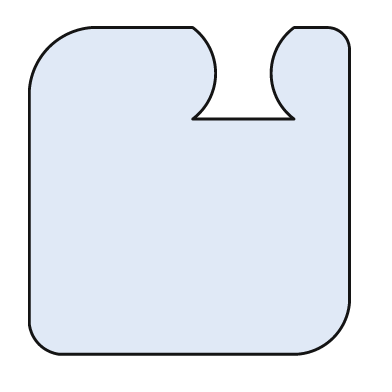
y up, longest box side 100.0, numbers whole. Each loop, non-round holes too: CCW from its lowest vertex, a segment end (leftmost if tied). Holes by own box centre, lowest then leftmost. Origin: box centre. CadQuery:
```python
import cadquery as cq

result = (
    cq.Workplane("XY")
    .moveTo(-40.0, -50.0)
    .lineTo(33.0, -50.0)
    .threePointArc((44.0, -45.0), (49.0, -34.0))
    .lineTo(49.0, 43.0)
    .threePointArc((47.0, 48.0), (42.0, 50.0))
    .lineTo(32.0, 50.0)
    .threePointArc((25.0, 36.0), (32.0, 22.0))
    .lineTo(1.0, 22.0)
    .threePointArc((8.0, 36.0), (1.0, 50.0))
    .lineTo(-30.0, 50.0)
    .threePointArc((-43.0, 44.0), (-49.0, 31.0))
    .lineTo(-49.0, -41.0)
    .threePointArc((-46.0, -47.0), (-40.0, -50.0))
    .close()
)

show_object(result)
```